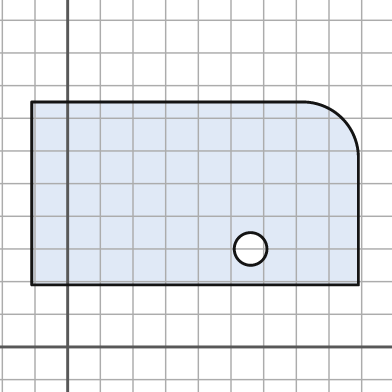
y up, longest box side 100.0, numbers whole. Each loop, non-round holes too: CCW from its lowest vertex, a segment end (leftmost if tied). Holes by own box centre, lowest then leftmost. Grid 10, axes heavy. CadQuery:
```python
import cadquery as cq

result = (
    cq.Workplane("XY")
    .moveTo(-11.0, 19.0)
    .lineTo(89.0, 19.0)
    .lineTo(89.0, 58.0)
    .threePointArc((84.0, 70.0), (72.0, 75.0))
    .lineTo(-11.0, 75.0)
    .close()
    .moveTo(56.0, 30.0)
    .circle(5.0)
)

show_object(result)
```